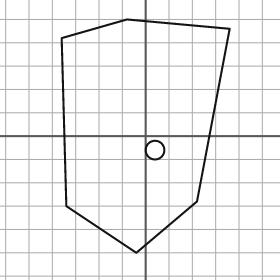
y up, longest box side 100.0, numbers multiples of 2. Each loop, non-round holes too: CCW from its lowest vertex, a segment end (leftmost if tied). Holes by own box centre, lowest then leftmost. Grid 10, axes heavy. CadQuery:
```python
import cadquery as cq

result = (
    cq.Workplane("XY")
    .moveTo(-4.0, -50.0)
    .lineTo(22.0, -28.0)
    .lineTo(36.0, 46.0)
    .lineTo(-8.0, 50.0)
    .lineTo(-36.0, 42.0)
    .lineTo(-34.0, -30.0)
    .close()
    .moveTo(4.0, -6.0)
    .circle(4.0)
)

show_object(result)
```